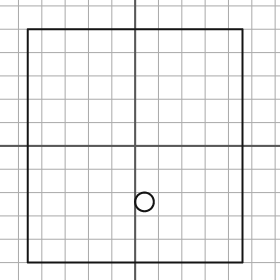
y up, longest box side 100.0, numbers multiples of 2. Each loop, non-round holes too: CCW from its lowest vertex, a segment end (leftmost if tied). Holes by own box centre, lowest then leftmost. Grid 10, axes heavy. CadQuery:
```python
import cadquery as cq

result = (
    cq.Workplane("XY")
    .moveTo(-46.0, -50.0)
    .lineTo(46.0, -50.0)
    .lineTo(46.0, 50.0)
    .lineTo(-46.0, 50.0)
    .close()
    .moveTo(4.0, -24.0)
    .circle(4.0)
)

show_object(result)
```